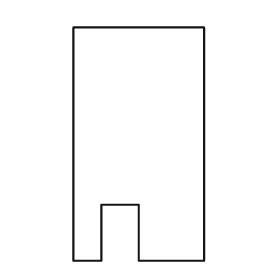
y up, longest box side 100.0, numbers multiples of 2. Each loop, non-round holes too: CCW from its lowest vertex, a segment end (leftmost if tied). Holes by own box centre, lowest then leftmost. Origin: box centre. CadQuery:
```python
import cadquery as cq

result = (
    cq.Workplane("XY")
    .moveTo(-28.0, -50.0)
    .lineTo(-16.0, -50.0)
    .lineTo(-16.0, -26.0)
    .lineTo(0.0, -26.0)
    .lineTo(0.0, -50.0)
    .lineTo(28.0, -50.0)
    .lineTo(28.0, 50.0)
    .lineTo(-28.0, 50.0)
    .close()
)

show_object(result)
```